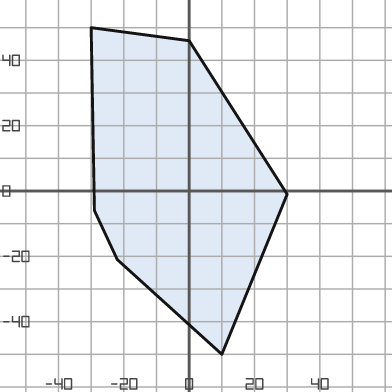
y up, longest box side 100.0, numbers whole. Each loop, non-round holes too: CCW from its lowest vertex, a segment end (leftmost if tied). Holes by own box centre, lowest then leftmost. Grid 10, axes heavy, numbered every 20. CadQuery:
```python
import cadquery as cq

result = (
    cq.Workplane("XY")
    .moveTo(10.0, -50.0)
    .lineTo(30.0, -1.0)
    .lineTo(0.0, 46.0)
    .lineTo(-30.0, 50.0)
    .lineTo(-29.0, -6.0)
    .lineTo(-22.0, -21.0)
    .close()
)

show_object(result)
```